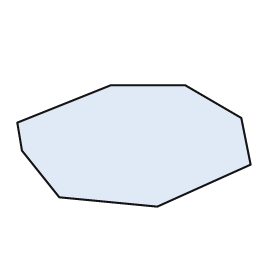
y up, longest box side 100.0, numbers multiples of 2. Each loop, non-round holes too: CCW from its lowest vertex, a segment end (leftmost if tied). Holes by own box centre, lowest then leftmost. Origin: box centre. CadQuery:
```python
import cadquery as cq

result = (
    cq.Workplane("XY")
    .moveTo(10.0, -26.0)
    .lineTo(50.0, -8.0)
    .lineTo(46.0, 12.0)
    .lineTo(22.0, 26.0)
    .lineTo(-10.0, 26.0)
    .lineTo(-50.0, 10.0)
    .lineTo(-48.0, -2.0)
    .lineTo(-32.0, -22.0)
    .close()
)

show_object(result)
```